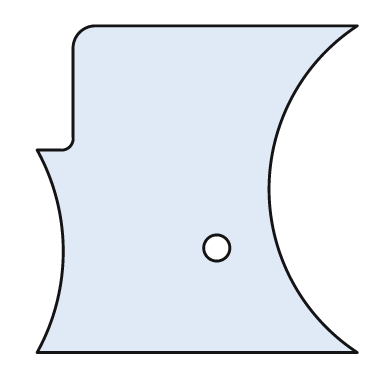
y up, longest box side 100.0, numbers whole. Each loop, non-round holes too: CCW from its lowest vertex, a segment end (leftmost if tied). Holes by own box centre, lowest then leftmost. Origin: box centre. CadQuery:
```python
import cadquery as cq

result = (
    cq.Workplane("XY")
    .moveTo(-49.0, -50.0)
    .lineTo(49.0, -50.0)
    .threePointArc((22.0, 0.0), (49.0, 50.0))
    .lineTo(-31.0, 50.0)
    .threePointArc((-36.0, 48.0), (-38.0, 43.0))
    .lineTo(-38.0, 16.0)
    .threePointArc((-39.0, 13.0), (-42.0, 12.0))
    .lineTo(-49.0, 12.0)
    .threePointArc((-41.0, -19.0), (-49.0, -50.0))
    .close()
    .moveTo(6.0, -18.0)
    .circle(4.0)
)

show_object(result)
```